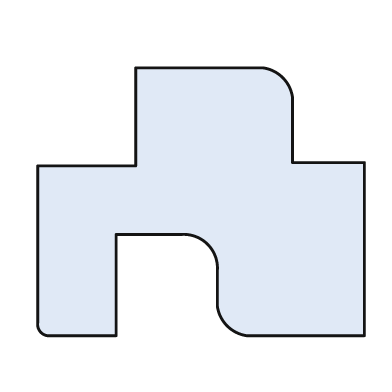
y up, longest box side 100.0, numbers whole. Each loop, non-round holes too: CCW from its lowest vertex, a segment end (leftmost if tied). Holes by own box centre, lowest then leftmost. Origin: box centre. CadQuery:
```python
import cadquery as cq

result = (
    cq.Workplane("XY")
    .moveTo(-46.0, -41.0)
    .lineTo(-26.0, -41.0)
    .lineTo(-26.0, -10.0)
    .lineTo(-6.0, -10.0)
    .threePointArc((2.0, -13.0), (5.0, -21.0))
    .lineTo(5.0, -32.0)
    .threePointArc((8.0, -38.0), (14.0, -41.0))
    .lineTo(50.0, -41.0)
    .lineTo(50.0, 12.0)
    .lineTo(28.0, 12.0)
    .lineTo(28.0, 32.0)
    .threePointArc((25.0, 38.0), (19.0, 41.0))
    .lineTo(-20.0, 41.0)
    .lineTo(-20.0, 11.0)
    .lineTo(-50.0, 11.0)
    .lineTo(-50.0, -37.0)
    .threePointArc((-49.0, -40.0), (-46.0, -41.0))
    .close()
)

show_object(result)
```